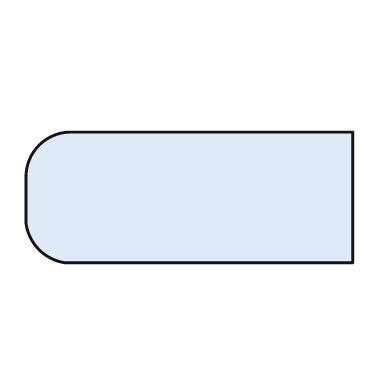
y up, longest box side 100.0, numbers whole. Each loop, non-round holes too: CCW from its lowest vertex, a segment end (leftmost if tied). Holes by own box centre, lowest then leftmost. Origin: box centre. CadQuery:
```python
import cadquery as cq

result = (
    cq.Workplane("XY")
    .moveTo(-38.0, -20.0)
    .lineTo(50.0, -20.0)
    .lineTo(50.0, 20.0)
    .lineTo(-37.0, 20.0)
    .threePointArc((-46.0, 16.0), (-50.0, 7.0))
    .lineTo(-50.0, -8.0)
    .threePointArc((-46.0, -16.0), (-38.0, -20.0))
    .close()
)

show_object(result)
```